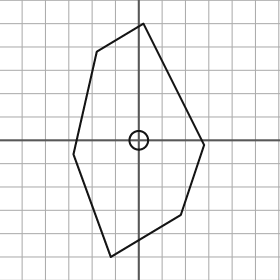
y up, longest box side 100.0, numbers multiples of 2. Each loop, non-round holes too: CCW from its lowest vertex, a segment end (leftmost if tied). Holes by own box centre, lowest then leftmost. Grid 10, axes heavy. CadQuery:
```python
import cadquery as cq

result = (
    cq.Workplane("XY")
    .moveTo(-12.0, -50.0)
    .lineTo(18.0, -32.0)
    .lineTo(28.0, -2.0)
    .lineTo(2.0, 50.0)
    .lineTo(-18.0, 38.0)
    .lineTo(-28.0, -6.0)
    .close()
    .moveTo(0.0, 0.0)
    .circle(4.0)
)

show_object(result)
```